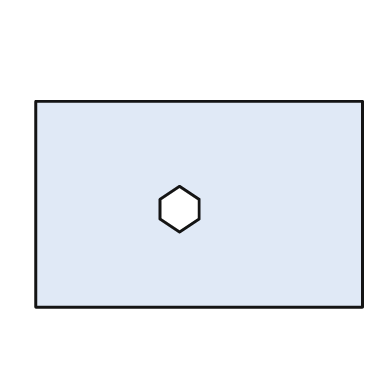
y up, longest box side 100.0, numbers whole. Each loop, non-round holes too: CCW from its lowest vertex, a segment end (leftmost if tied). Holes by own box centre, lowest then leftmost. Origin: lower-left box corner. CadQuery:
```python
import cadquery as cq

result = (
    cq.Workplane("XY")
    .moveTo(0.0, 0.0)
    .lineTo(100.0, 0.0)
    .lineTo(100.0, 63.0)
    .lineTo(0.0, 63.0)
    .close()
    .moveTo(44.0, 23.0)
    .lineTo(50.0, 27.0)
    .lineTo(50.0, 33.0)
    .lineTo(44.0, 37.0)
    .lineTo(38.0, 33.0)
    .lineTo(38.0, 27.0)
    .close()
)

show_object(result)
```